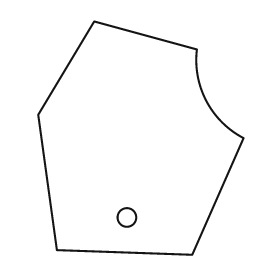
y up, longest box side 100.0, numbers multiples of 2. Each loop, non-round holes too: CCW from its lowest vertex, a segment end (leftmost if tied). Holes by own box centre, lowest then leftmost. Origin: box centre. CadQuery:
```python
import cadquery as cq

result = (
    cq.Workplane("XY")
    .moveTo(22.0, -50.0)
    .lineTo(44.0, 0.0)
    .threePointArc((28.0, 16.0), (24.0, 38.0))
    .lineTo(-20.0, 50.0)
    .lineTo(-44.0, 10.0)
    .lineTo(-36.0, -48.0)
    .close()
    .moveTo(-6.0, -34.0)
    .circle(4.0)
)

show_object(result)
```